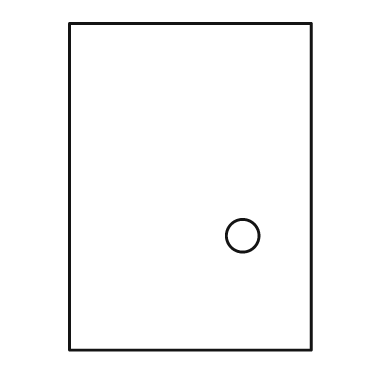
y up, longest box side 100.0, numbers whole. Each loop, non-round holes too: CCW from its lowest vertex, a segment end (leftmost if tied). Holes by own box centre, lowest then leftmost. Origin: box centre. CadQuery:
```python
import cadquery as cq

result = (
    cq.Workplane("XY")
    .moveTo(-37.0, -50.0)
    .lineTo(37.0, -50.0)
    .lineTo(37.0, 50.0)
    .lineTo(-37.0, 50.0)
    .close()
    .moveTo(16.0, -15.0)
    .circle(5.0)
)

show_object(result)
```